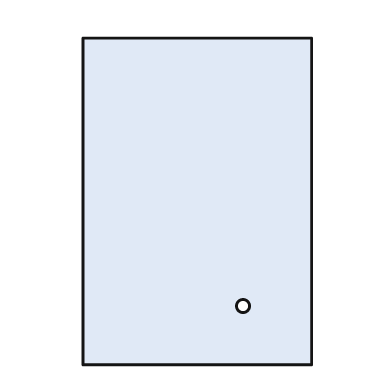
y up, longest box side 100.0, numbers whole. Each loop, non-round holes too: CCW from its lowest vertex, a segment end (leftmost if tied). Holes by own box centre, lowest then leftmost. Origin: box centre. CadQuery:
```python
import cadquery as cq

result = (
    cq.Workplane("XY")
    .moveTo(-35.0, -50.0)
    .lineTo(35.0, -50.0)
    .lineTo(35.0, 50.0)
    .lineTo(-35.0, 50.0)
    .close()
    .moveTo(14.0, -32.0)
    .circle(2.0)
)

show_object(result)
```